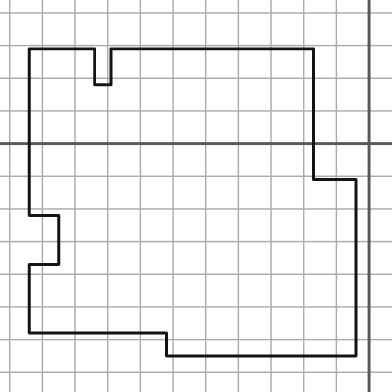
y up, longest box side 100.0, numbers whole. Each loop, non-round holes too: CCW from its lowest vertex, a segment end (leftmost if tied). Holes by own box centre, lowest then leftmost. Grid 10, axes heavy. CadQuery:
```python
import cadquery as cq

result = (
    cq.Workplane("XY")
    .moveTo(-62.0, -65.0)
    .lineTo(-4.0, -65.0)
    .lineTo(-4.0, -11.0)
    .lineTo(-17.0, -11.0)
    .lineTo(-17.0, 29.0)
    .lineTo(-79.0, 29.0)
    .lineTo(-79.0, 18.0)
    .lineTo(-84.0, 18.0)
    .lineTo(-84.0, 29.0)
    .lineTo(-104.0, 29.0)
    .lineTo(-104.0, -22.0)
    .lineTo(-95.0, -22.0)
    .lineTo(-95.0, -37.0)
    .lineTo(-104.0, -37.0)
    .lineTo(-104.0, -58.0)
    .lineTo(-62.0, -58.0)
    .close()
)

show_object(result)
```